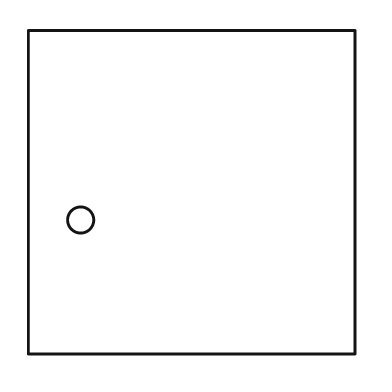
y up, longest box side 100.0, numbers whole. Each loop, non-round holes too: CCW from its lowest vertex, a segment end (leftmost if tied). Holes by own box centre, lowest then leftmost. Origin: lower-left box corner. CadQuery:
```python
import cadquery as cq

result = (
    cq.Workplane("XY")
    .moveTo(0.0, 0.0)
    .lineTo(100.0, 0.0)
    .lineTo(100.0, 99.0)
    .lineTo(0.0, 99.0)
    .close()
    .moveTo(16.0, 41.0)
    .circle(4.0)
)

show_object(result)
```